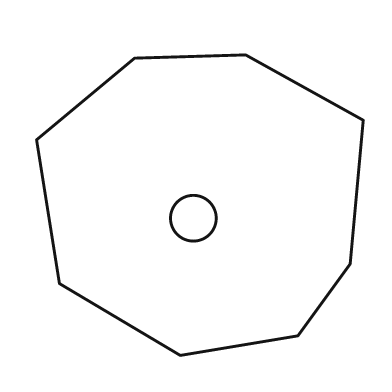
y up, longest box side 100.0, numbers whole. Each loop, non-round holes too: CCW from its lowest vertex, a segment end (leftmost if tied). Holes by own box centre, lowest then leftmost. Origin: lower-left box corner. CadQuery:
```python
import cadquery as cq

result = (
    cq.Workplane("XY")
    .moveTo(44.0, 0.0)
    .lineTo(80.0, 6.0)
    .lineTo(96.0, 28.0)
    .lineTo(100.0, 72.0)
    .lineTo(64.0, 92.0)
    .lineTo(30.0, 91.0)
    .lineTo(0.0, 66.0)
    .lineTo(7.0, 22.0)
    .close()
    .moveTo(48.0, 42.0)
    .circle(7.0)
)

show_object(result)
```